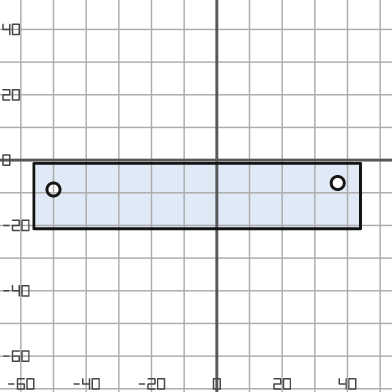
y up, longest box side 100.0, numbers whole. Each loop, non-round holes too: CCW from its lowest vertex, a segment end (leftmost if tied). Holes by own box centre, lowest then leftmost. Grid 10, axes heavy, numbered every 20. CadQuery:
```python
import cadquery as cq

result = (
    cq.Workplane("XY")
    .moveTo(-56.0, -21.0)
    .lineTo(44.0, -21.0)
    .lineTo(44.0, -1.0)
    .lineTo(-56.0, -1.0)
    .close()
    .moveTo(-50.0, -9.0)
    .circle(2.0)
    .moveTo(37.0, -7.0)
    .circle(2.0)
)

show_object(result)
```